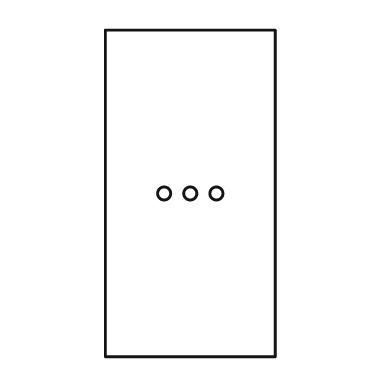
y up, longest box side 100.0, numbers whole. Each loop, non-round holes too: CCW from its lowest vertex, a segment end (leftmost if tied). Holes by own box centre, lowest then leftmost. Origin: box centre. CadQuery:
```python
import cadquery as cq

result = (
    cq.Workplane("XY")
    .moveTo(-26.0, -50.0)
    .lineTo(26.0, -50.0)
    .lineTo(26.0, 50.0)
    .lineTo(-26.0, 50.0)
    .close()
    .moveTo(-8.0, 0.0)
    .circle(2.0)
    .moveTo(0.0, 0.0)
    .circle(2.0)
    .moveTo(8.0, 0.0)
    .circle(2.0)
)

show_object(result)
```